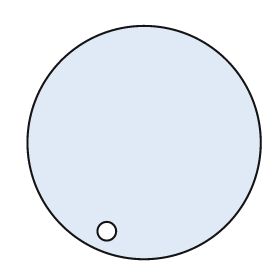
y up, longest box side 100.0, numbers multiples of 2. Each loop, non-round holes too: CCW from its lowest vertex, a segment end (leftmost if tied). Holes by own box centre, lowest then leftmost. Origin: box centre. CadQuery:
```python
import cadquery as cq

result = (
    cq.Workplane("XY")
    .moveTo(0.0, 0.0)
    .circle(50.0)
    .moveTo(-16.0, -38.0)
    .circle(4.0)
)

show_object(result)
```